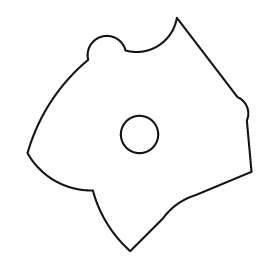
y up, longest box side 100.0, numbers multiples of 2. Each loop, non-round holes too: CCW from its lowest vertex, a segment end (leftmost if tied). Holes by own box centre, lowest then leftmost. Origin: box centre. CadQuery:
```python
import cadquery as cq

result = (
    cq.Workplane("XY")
    .moveTo(-4.0, -50.0)
    .lineTo(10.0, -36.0)
    .threePointArc((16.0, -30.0), (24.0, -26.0))
    .lineTo(48.0, -16.0)
    .lineTo(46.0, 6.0)
    .threePointArc((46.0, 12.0), (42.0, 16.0))
    .lineTo(16.0, 50.0)
    .threePointArc((8.0, 38.0), (-6.0, 36.0))
    .threePointArc((-16.0, 42.0), (-22.0, 32.0))
    .threePointArc((-38.0, 14.0), (-48.0, -8.0))
    .threePointArc((-36.0, -20.0), (-20.0, -24.0))
    .threePointArc((-14.0, -38.0), (-4.0, -50.0))
    .close()
    .moveTo(0.0, 0.0)
    .circle(8.0)
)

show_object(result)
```